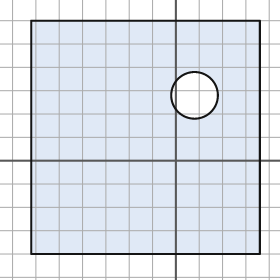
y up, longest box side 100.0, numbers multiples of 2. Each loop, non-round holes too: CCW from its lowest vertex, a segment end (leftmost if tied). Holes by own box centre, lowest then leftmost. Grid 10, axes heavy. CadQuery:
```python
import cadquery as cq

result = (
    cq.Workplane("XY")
    .moveTo(-62.0, -40.0)
    .lineTo(36.0, -40.0)
    .lineTo(36.0, 60.0)
    .lineTo(-62.0, 60.0)
    .close()
    .moveTo(8.0, 28.0)
    .circle(10.0)
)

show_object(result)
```